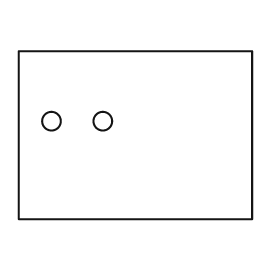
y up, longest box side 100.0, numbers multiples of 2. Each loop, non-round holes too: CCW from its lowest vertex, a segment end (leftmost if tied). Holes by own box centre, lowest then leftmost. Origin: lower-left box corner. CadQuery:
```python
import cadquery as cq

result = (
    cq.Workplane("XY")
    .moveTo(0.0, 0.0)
    .lineTo(100.0, 0.0)
    .lineTo(100.0, 72.0)
    .lineTo(0.0, 72.0)
    .close()
    .moveTo(14.0, 42.0)
    .circle(4.0)
    .moveTo(36.0, 42.0)
    .circle(4.0)
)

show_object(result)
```